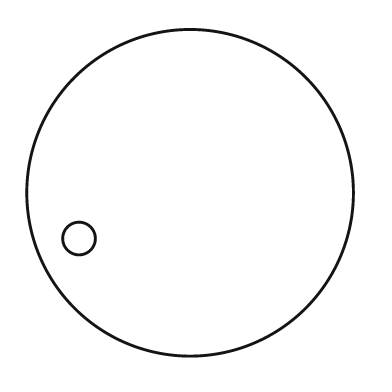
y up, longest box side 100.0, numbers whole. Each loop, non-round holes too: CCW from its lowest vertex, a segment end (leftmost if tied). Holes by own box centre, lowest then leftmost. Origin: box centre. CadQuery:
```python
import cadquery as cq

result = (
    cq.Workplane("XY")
    .moveTo(0.0, 0.0)
    .circle(50.0)
    .moveTo(-34.0, -14.0)
    .circle(5.0)
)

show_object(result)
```